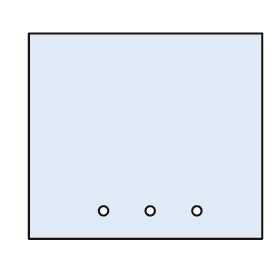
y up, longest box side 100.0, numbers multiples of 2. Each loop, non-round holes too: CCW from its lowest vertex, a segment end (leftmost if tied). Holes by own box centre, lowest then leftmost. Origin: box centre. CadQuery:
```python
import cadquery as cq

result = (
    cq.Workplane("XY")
    .moveTo(-50.0, -44.0)
    .lineTo(50.0, -44.0)
    .lineTo(50.0, 44.0)
    .lineTo(-50.0, 44.0)
    .close()
    .moveTo(-18.0, -32.0)
    .circle(2.0)
    .moveTo(2.0, -32.0)
    .circle(2.0)
    .moveTo(22.0, -32.0)
    .circle(2.0)
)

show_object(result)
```